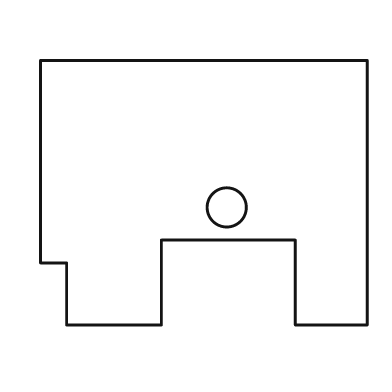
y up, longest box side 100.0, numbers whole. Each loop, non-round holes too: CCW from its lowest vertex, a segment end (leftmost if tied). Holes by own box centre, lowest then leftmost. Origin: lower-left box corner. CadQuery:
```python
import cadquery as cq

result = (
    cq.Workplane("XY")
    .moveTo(8.0, 0.0)
    .lineTo(37.0, 0.0)
    .lineTo(37.0, 26.0)
    .lineTo(78.0, 26.0)
    .lineTo(78.0, 0.0)
    .lineTo(100.0, 0.0)
    .lineTo(100.0, 81.0)
    .lineTo(0.0, 81.0)
    .lineTo(0.0, 19.0)
    .lineTo(8.0, 19.0)
    .close()
    .moveTo(57.0, 36.0)
    .circle(6.0)
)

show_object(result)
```